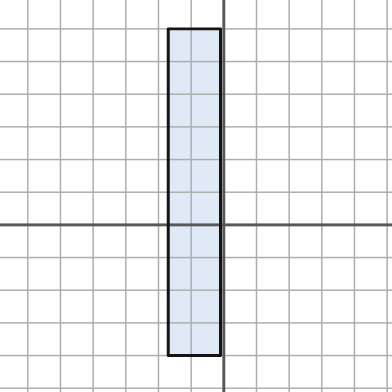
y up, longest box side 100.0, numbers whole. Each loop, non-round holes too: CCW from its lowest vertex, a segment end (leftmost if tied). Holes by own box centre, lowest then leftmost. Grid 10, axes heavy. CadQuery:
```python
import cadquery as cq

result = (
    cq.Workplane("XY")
    .moveTo(-17.0, -40.0)
    .lineTo(-1.0, -40.0)
    .lineTo(-1.0, 60.0)
    .lineTo(-17.0, 60.0)
    .close()
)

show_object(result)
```